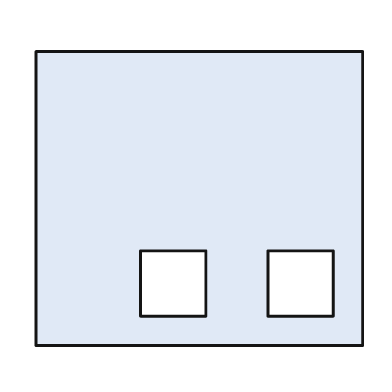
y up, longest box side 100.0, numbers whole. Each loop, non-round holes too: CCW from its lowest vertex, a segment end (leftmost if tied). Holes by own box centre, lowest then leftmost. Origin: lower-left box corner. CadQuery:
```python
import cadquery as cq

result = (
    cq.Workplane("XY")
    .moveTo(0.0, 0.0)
    .lineTo(100.0, 0.0)
    .lineTo(100.0, 90.0)
    .lineTo(0.0, 90.0)
    .close()
    .moveTo(32.0, 9.0)
    .lineTo(52.0, 9.0)
    .lineTo(52.0, 29.0)
    .lineTo(32.0, 29.0)
    .close()
    .moveTo(71.0, 9.0)
    .lineTo(91.0, 9.0)
    .lineTo(91.0, 29.0)
    .lineTo(71.0, 29.0)
    .close()
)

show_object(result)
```